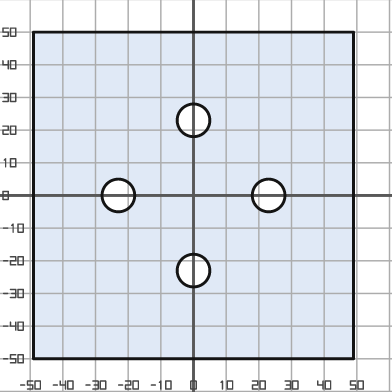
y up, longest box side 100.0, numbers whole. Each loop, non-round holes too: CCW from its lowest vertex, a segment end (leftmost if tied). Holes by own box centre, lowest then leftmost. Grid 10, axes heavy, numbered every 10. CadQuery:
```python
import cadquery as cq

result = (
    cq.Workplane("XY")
    .moveTo(-49.0, -50.0)
    .lineTo(49.0, -50.0)
    .lineTo(49.0, 50.0)
    .lineTo(-49.0, 50.0)
    .close()
    .moveTo(0.0, -23.0)
    .circle(5.0)
    .moveTo(-23.0, 0.0)
    .circle(5.0)
    .moveTo(23.0, 0.0)
    .circle(5.0)
    .moveTo(0.0, 23.0)
    .circle(5.0)
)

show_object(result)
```